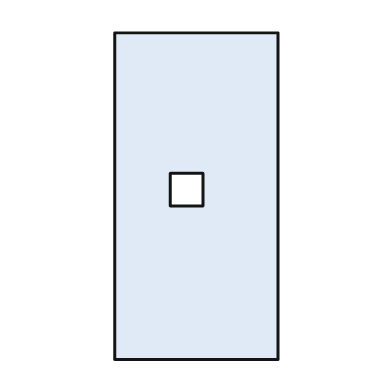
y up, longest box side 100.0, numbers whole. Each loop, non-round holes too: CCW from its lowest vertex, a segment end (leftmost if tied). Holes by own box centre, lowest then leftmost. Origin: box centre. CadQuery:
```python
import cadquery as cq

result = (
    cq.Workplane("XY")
    .moveTo(-25.0, -50.0)
    .lineTo(25.0, -50.0)
    .lineTo(25.0, 50.0)
    .lineTo(-25.0, 50.0)
    .close()
    .moveTo(-8.0, -3.0)
    .lineTo(2.0, -3.0)
    .lineTo(2.0, 7.0)
    .lineTo(-8.0, 7.0)
    .close()
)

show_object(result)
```